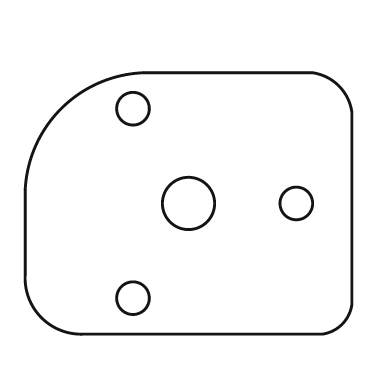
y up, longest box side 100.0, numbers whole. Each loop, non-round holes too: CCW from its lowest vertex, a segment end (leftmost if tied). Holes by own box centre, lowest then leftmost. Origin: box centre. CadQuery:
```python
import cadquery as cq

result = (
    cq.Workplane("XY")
    .moveTo(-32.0, -40.0)
    .lineTo(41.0, -40.0)
    .threePointArc((47.0, -37.0), (50.0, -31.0))
    .lineTo(50.0, 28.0)
    .threePointArc((46.0, 36.0), (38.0, 40.0))
    .lineTo(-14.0, 40.0)
    .threePointArc((-39.0, 29.0), (-50.0, 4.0))
    .lineTo(-50.0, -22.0)
    .threePointArc((-45.0, -35.0), (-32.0, -40.0))
    .close()
    .moveTo(-17.0, -29.0)
    .circle(5.0)
    .moveTo(0.0, 0.0)
    .circle(8.0)
    .moveTo(33.0, 0.0)
    .circle(5.0)
    .moveTo(-17.0, 29.0)
    .circle(5.0)
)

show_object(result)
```